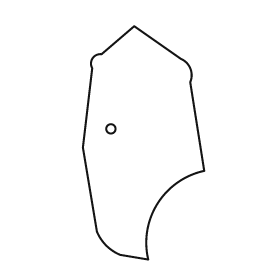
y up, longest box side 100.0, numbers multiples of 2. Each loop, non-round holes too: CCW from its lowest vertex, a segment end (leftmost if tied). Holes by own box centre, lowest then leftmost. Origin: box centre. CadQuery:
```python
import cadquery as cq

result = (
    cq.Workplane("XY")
    .moveTo(2.0, -50.0)
    .threePointArc((6.0, -26.0), (26.0, -12.0))
    .lineTo(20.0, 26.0)
    .threePointArc((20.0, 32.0), (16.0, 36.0))
    .lineTo(-4.0, 50.0)
    .lineTo(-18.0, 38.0)
    .threePointArc((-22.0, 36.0), (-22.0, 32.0))
    .lineTo(-26.0, -2.0)
    .lineTo(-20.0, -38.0)
    .threePointArc((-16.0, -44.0), (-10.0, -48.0))
    .close()
    .moveTo(-14.0, 6.0)
    .circle(2.0)
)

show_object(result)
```